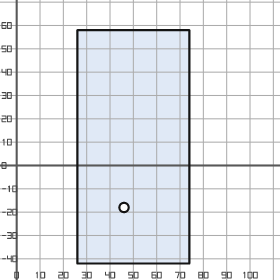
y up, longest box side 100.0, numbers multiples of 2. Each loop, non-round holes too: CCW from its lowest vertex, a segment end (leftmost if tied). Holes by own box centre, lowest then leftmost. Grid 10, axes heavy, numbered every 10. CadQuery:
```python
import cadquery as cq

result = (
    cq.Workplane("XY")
    .moveTo(26.0, -42.0)
    .lineTo(74.0, -42.0)
    .lineTo(74.0, 58.0)
    .lineTo(26.0, 58.0)
    .close()
    .moveTo(46.0, -18.0)
    .circle(2.0)
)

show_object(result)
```